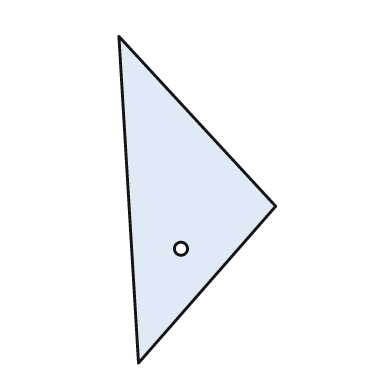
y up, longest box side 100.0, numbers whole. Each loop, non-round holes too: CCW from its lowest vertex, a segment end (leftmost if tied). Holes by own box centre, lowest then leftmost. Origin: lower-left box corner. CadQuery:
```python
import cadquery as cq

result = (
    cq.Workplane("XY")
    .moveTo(6.0, 0.0)
    .lineTo(48.0, 48.0)
    .lineTo(0.0, 100.0)
    .close()
    .moveTo(19.0, 35.0)
    .circle(2.0)
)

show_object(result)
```